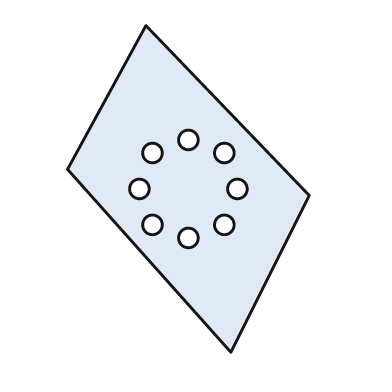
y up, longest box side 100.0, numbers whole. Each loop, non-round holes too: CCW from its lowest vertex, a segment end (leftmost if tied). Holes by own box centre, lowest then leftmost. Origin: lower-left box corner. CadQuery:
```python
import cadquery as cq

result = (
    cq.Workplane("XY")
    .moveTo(50.0, 0.0)
    .lineTo(74.0, 48.0)
    .lineTo(24.0, 100.0)
    .lineTo(0.0, 56.0)
    .close()
    .moveTo(37.0, 35.0)
    .circle(3.0)
    .moveTo(26.0, 39.0)
    .circle(3.0)
    .moveTo(48.0, 39.0)
    .circle(3.0)
    .moveTo(22.0, 50.0)
    .circle(3.0)
    .moveTo(52.0, 50.0)
    .circle(3.0)
    .moveTo(26.0, 61.0)
    .circle(3.0)
    .moveTo(48.0, 61.0)
    .circle(3.0)
    .moveTo(37.0, 65.0)
    .circle(3.0)
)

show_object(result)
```